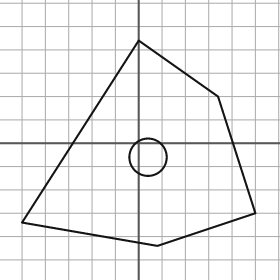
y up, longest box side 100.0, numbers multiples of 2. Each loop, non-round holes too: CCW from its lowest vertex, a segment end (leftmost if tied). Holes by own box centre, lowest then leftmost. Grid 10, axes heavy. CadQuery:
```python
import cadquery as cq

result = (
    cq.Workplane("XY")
    .moveTo(8.0, -44.0)
    .lineTo(50.0, -30.0)
    .lineTo(34.0, 20.0)
    .lineTo(0.0, 44.0)
    .lineTo(-50.0, -34.0)
    .close()
    .moveTo(4.0, -6.0)
    .circle(8.0)
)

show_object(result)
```